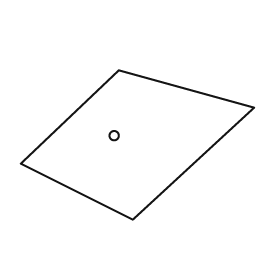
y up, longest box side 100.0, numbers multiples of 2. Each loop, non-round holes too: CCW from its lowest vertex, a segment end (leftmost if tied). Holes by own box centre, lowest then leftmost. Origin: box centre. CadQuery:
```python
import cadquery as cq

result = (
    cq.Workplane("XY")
    .moveTo(-2.0, -32.0)
    .lineTo(50.0, 16.0)
    .lineTo(-8.0, 32.0)
    .lineTo(-50.0, -8.0)
    .close()
    .moveTo(-10.0, 4.0)
    .circle(2.0)
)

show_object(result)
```